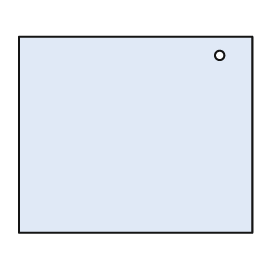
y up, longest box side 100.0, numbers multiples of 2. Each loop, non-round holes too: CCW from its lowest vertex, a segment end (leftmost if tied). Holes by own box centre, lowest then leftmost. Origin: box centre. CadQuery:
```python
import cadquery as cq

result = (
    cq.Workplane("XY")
    .moveTo(-50.0, -42.0)
    .lineTo(50.0, -42.0)
    .lineTo(50.0, 42.0)
    .lineTo(-50.0, 42.0)
    .close()
    .moveTo(36.0, 34.0)
    .circle(2.0)
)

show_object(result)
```